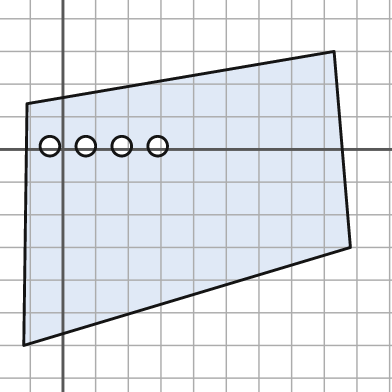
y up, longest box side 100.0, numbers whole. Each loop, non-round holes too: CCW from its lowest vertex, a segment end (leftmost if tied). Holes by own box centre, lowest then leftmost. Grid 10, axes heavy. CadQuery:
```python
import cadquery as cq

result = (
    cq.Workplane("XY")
    .moveTo(-12.0, -60.0)
    .lineTo(88.0, -30.0)
    .lineTo(83.0, 30.0)
    .lineTo(-11.0, 14.0)
    .close()
    .moveTo(-4.0, 1.0)
    .circle(3.0)
    .moveTo(7.0, 1.0)
    .circle(3.0)
    .moveTo(18.0, 1.0)
    .circle(3.0)
    .moveTo(29.0, 1.0)
    .circle(3.0)
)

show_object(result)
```